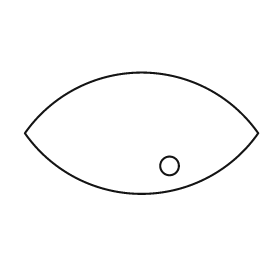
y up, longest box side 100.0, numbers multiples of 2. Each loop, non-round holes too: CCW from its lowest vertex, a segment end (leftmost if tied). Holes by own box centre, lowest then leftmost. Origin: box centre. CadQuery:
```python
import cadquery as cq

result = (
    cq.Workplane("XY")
    .moveTo(-50.0, 0.0)
    .threePointArc((0.0, -26.0), (50.0, 0.0))
    .threePointArc((0.0, 26.0), (-50.0, 0.0))
    .close()
    .moveTo(12.0, -14.0)
    .circle(4.0)
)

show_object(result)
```